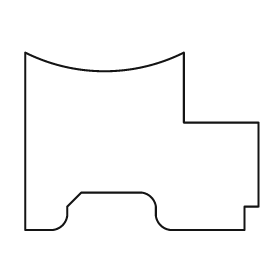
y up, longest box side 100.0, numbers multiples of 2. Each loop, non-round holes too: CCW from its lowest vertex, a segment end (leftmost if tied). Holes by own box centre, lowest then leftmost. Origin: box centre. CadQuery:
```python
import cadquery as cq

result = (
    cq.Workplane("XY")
    .moveTo(-50.0, -38.0)
    .lineTo(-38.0, -38.0)
    .threePointArc((-34.0, -36.0), (-32.0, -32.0))
    .lineTo(-32.0, -28.0)
    .lineTo(-26.0, -22.0)
    .lineTo(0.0, -22.0)
    .threePointArc((4.0, -24.0), (6.0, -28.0))
    .lineTo(6.0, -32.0)
    .threePointArc((8.0, -36.0), (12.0, -38.0))
    .lineTo(44.0, -38.0)
    .lineTo(44.0, -28.0)
    .lineTo(50.0, -28.0)
    .lineTo(50.0, 8.0)
    .lineTo(18.0, 8.0)
    .lineTo(18.0, 38.0)
    .threePointArc((-16.0, 30.0), (-50.0, 38.0))
    .close()
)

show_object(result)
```